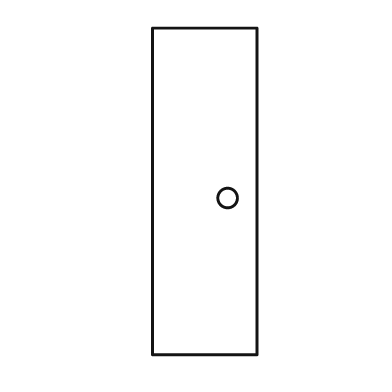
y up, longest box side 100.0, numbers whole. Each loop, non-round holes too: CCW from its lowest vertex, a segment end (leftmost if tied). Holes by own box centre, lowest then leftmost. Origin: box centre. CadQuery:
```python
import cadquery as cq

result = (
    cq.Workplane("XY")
    .moveTo(-16.0, -50.0)
    .lineTo(16.0, -50.0)
    .lineTo(16.0, 50.0)
    .lineTo(-16.0, 50.0)
    .close()
    .moveTo(7.0, -2.0)
    .circle(3.0)
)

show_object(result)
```